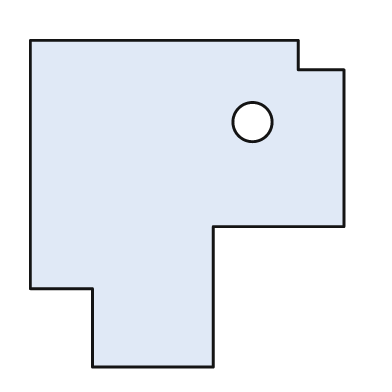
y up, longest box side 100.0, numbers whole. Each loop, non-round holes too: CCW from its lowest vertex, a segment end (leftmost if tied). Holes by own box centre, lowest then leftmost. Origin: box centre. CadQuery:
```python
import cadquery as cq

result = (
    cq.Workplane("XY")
    .moveTo(-29.0, -50.0)
    .lineTo(8.0, -50.0)
    .lineTo(8.0, -7.0)
    .lineTo(48.0, -7.0)
    .lineTo(48.0, 41.0)
    .lineTo(34.0, 41.0)
    .lineTo(34.0, 50.0)
    .lineTo(-48.0, 50.0)
    .lineTo(-48.0, -26.0)
    .lineTo(-29.0, -26.0)
    .close()
    .moveTo(20.0, 25.0)
    .circle(6.0)
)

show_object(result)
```